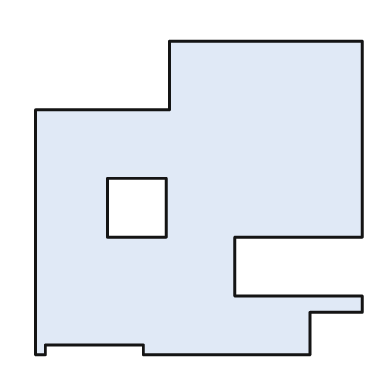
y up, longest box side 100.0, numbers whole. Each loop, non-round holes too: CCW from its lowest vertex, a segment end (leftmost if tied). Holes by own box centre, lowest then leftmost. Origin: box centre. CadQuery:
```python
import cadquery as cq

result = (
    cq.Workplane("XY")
    .moveTo(-50.0, -48.0)
    .lineTo(-47.0, -48.0)
    .lineTo(-47.0, -45.0)
    .lineTo(-17.0, -45.0)
    .lineTo(-17.0, -48.0)
    .lineTo(34.0, -48.0)
    .lineTo(34.0, -35.0)
    .lineTo(50.0, -35.0)
    .lineTo(50.0, -30.0)
    .lineTo(11.0, -30.0)
    .lineTo(11.0, -12.0)
    .lineTo(50.0, -12.0)
    .lineTo(50.0, 48.0)
    .lineTo(-9.0, 48.0)
    .lineTo(-9.0, 27.0)
    .lineTo(-50.0, 27.0)
    .close()
    .moveTo(-28.0, -12.0)
    .lineTo(-10.0, -12.0)
    .lineTo(-10.0, 6.0)
    .lineTo(-28.0, 6.0)
    .close()
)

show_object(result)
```